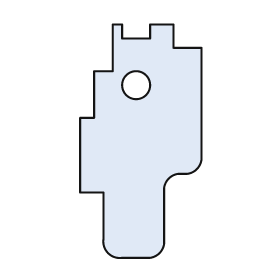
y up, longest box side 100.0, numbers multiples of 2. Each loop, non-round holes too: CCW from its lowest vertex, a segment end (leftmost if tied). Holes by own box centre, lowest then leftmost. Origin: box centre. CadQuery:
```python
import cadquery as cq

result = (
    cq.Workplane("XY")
    .moveTo(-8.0, -50.0)
    .lineTo(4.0, -50.0)
    .threePointArc((8.0, -48.0), (10.0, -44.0))
    .lineTo(10.0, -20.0)
    .threePointArc((12.0, -16.0), (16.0, -14.0))
    .lineTo(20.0, -14.0)
    .threePointArc((24.0, -12.0), (26.0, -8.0))
    .lineTo(26.0, 40.0)
    .lineTo(14.0, 40.0)
    .lineTo(14.0, 50.0)
    .lineTo(4.0, 50.0)
    .lineTo(4.0, 44.0)
    .lineTo(-8.0, 44.0)
    .lineTo(-8.0, 50.0)
    .lineTo(-12.0, 50.0)
    .lineTo(-12.0, 30.0)
    .lineTo(-20.0, 30.0)
    .lineTo(-20.0, 10.0)
    .lineTo(-26.0, 10.0)
    .lineTo(-26.0, -22.0)
    .lineTo(-16.0, -22.0)
    .lineTo(-16.0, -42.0)
    .threePointArc((-14.0, -48.0), (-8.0, -50.0))
    .close()
    .moveTo(-2.0, 24.0)
    .circle(6.0)
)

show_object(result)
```